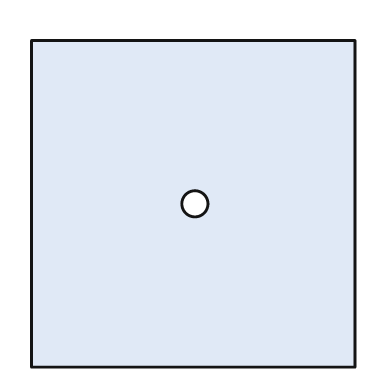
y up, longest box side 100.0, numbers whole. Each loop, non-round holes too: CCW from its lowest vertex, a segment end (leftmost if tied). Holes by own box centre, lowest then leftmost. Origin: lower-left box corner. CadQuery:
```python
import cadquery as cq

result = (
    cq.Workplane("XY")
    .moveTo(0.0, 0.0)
    .lineTo(99.0, 0.0)
    .lineTo(99.0, 100.0)
    .lineTo(0.0, 100.0)
    .close()
    .moveTo(50.0, 50.0)
    .circle(4.0)
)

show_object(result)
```